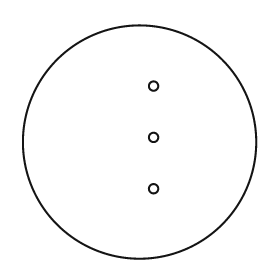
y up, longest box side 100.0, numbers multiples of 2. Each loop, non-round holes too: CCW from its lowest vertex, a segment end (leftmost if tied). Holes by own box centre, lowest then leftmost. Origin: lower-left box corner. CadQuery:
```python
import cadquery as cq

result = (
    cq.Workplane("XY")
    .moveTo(50.0, 50.0)
    .circle(50.0)
    .moveTo(56.0, 30.0)
    .circle(2.0)
    .moveTo(56.0, 52.0)
    .circle(2.0)
    .moveTo(56.0, 74.0)
    .circle(2.0)
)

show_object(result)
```